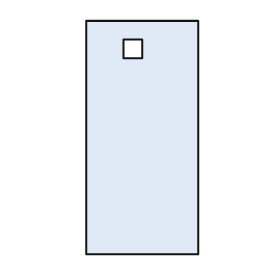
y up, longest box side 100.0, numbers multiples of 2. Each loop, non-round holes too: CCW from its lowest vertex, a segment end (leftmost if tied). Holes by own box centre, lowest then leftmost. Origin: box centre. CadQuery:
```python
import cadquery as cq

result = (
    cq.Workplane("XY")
    .moveTo(-24.0, -50.0)
    .lineTo(24.0, -50.0)
    .lineTo(24.0, 50.0)
    .lineTo(-24.0, 50.0)
    .close()
    .moveTo(-8.0, 34.0)
    .lineTo(0.0, 34.0)
    .lineTo(0.0, 42.0)
    .lineTo(-8.0, 42.0)
    .close()
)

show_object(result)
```